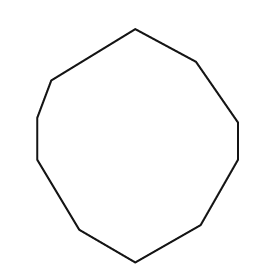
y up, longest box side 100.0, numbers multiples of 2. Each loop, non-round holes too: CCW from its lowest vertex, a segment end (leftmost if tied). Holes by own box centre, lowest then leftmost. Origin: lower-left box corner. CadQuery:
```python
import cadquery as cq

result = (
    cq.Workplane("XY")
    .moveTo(42.0, 0.0)
    .lineTo(70.0, 16.0)
    .lineTo(86.0, 44.0)
    .lineTo(86.0, 60.0)
    .lineTo(68.0, 86.0)
    .lineTo(42.0, 100.0)
    .lineTo(6.0, 78.0)
    .lineTo(0.0, 62.0)
    .lineTo(0.0, 44.0)
    .lineTo(18.0, 14.0)
    .close()
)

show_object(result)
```